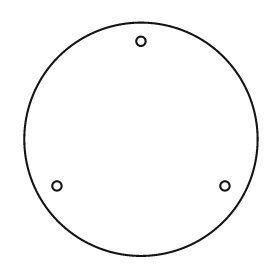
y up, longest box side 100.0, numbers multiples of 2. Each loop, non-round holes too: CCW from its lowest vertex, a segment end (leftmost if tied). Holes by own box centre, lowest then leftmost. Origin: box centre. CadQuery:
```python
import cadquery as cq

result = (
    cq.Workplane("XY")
    .moveTo(0.0, 0.0)
    .circle(50.0)
    .moveTo(-36.0, -20.0)
    .circle(2.0)
    .moveTo(36.0, -20.0)
    .circle(2.0)
    .moveTo(0.0, 42.0)
    .circle(2.0)
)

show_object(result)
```